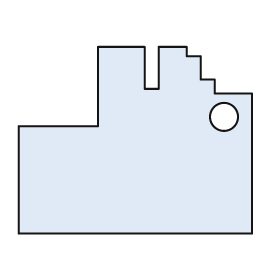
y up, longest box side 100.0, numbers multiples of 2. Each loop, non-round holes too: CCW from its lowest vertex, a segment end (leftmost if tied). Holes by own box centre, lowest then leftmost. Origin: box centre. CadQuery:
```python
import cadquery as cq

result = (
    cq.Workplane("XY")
    .moveTo(-50.0, -40.0)
    .lineTo(50.0, -40.0)
    .lineTo(50.0, 20.0)
    .lineTo(34.0, 20.0)
    .lineTo(34.0, 26.0)
    .lineTo(28.0, 26.0)
    .lineTo(28.0, 36.0)
    .lineTo(22.0, 36.0)
    .lineTo(22.0, 40.0)
    .lineTo(10.0, 40.0)
    .lineTo(10.0, 22.0)
    .lineTo(4.0, 22.0)
    .lineTo(4.0, 40.0)
    .lineTo(-16.0, 40.0)
    .lineTo(-16.0, 6.0)
    .lineTo(-50.0, 6.0)
    .close()
    .moveTo(38.0, 10.0)
    .circle(6.0)
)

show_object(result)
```